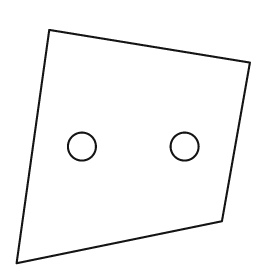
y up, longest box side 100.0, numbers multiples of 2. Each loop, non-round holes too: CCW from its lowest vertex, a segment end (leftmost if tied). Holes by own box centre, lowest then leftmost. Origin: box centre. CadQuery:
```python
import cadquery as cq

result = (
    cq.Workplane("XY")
    .moveTo(-50.0, -50.0)
    .lineTo(38.0, -32.0)
    .lineTo(50.0, 36.0)
    .lineTo(-36.0, 50.0)
    .close()
    .moveTo(-22.0, 0.0)
    .circle(6.0)
    .moveTo(22.0, 0.0)
    .circle(6.0)
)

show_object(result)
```